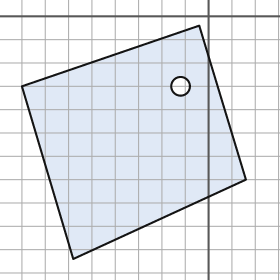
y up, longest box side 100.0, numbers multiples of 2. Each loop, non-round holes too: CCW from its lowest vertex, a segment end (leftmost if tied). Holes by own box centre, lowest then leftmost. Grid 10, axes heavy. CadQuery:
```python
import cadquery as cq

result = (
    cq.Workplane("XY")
    .moveTo(-58.0, -104.0)
    .lineTo(16.0, -70.0)
    .lineTo(-4.0, -4.0)
    .lineTo(-80.0, -30.0)
    .close()
    .moveTo(-12.0, -30.0)
    .circle(4.0)
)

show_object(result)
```